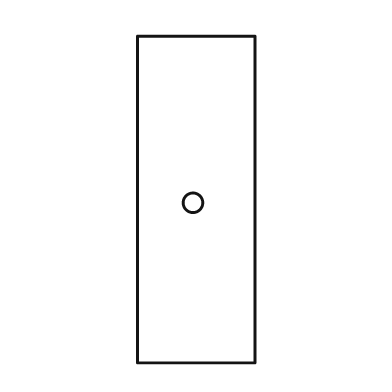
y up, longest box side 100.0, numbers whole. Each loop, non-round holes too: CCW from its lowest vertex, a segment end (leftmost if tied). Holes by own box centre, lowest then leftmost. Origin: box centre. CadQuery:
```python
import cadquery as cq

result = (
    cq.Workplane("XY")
    .moveTo(-18.0, -50.0)
    .lineTo(18.0, -50.0)
    .lineTo(18.0, 50.0)
    .lineTo(-18.0, 50.0)
    .close()
    .moveTo(-1.0, -1.0)
    .circle(3.0)
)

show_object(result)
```